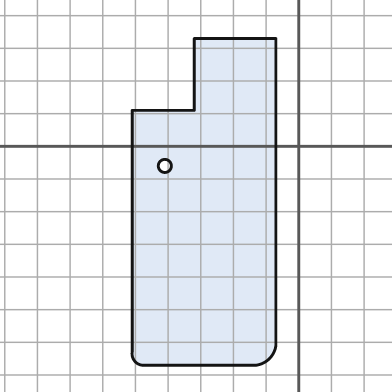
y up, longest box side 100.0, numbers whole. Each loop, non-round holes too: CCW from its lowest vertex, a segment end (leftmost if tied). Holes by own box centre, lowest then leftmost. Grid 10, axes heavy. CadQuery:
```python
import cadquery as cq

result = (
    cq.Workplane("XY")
    .moveTo(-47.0, -67.0)
    .lineTo(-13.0, -67.0)
    .threePointArc((-9.0, -65.0), (-7.0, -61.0))
    .lineTo(-7.0, 33.0)
    .lineTo(-32.0, 33.0)
    .lineTo(-32.0, 11.0)
    .lineTo(-51.0, 11.0)
    .lineTo(-51.0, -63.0)
    .threePointArc((-50.0, -66.0), (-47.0, -67.0))
    .close()
    .moveTo(-41.0, -6.0)
    .circle(2.0)
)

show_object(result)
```